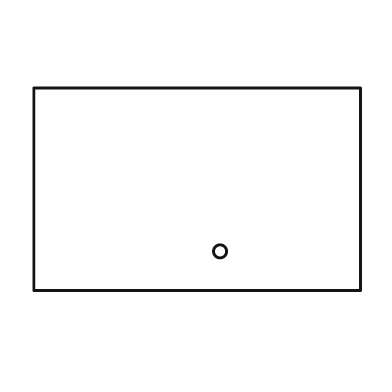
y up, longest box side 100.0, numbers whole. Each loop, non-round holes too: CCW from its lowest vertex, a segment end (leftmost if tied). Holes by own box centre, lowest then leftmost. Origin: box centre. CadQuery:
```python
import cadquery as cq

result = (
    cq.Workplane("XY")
    .moveTo(-50.0, -31.0)
    .lineTo(50.0, -31.0)
    .lineTo(50.0, 31.0)
    .lineTo(-50.0, 31.0)
    .close()
    .moveTo(7.0, -19.0)
    .circle(2.0)
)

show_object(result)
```